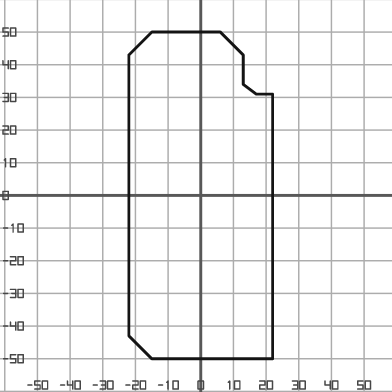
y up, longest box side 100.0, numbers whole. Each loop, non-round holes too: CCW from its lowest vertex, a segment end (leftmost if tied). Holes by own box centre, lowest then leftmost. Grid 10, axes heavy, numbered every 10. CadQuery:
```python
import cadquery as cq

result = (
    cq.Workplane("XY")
    .moveTo(-15.0, -50.0)
    .lineTo(22.0, -50.0)
    .lineTo(22.0, 31.0)
    .lineTo(17.0, 31.0)
    .lineTo(13.0, 34.0)
    .lineTo(13.0, 43.0)
    .lineTo(6.0, 50.0)
    .lineTo(-15.0, 50.0)
    .lineTo(-22.0, 43.0)
    .lineTo(-22.0, -43.0)
    .close()
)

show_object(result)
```